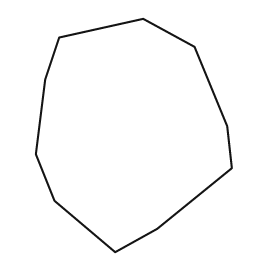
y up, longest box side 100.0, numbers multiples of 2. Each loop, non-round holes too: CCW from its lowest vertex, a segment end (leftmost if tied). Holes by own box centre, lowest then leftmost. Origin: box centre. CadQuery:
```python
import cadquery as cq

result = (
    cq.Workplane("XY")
    .moveTo(-8.0, -50.0)
    .lineTo(10.0, -40.0)
    .lineTo(42.0, -14.0)
    .lineTo(40.0, 4.0)
    .lineTo(26.0, 38.0)
    .lineTo(4.0, 50.0)
    .lineTo(-32.0, 42.0)
    .lineTo(-38.0, 24.0)
    .lineTo(-42.0, -8.0)
    .lineTo(-34.0, -28.0)
    .close()
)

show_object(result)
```